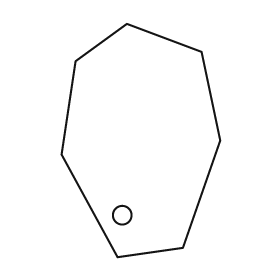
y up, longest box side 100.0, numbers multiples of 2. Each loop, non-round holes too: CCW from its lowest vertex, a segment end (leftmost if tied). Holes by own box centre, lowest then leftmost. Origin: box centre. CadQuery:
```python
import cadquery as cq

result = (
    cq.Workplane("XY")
    .moveTo(-10.0, -50.0)
    .lineTo(18.0, -46.0)
    .lineTo(34.0, 0.0)
    .lineTo(26.0, 38.0)
    .lineTo(-6.0, 50.0)
    .lineTo(-28.0, 34.0)
    .lineTo(-34.0, -6.0)
    .close()
    .moveTo(-8.0, -32.0)
    .circle(4.0)
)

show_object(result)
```